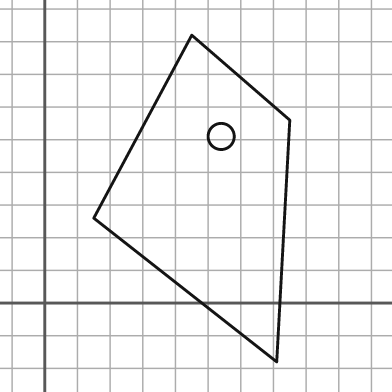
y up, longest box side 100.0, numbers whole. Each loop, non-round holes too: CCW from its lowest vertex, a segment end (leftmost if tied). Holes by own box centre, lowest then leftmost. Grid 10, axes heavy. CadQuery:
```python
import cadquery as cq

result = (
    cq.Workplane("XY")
    .moveTo(71.0, -18.0)
    .lineTo(75.0, 56.0)
    .lineTo(45.0, 82.0)
    .lineTo(15.0, 26.0)
    .close()
    .moveTo(54.0, 51.0)
    .circle(4.0)
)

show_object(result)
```